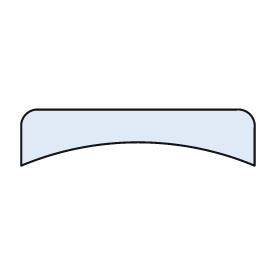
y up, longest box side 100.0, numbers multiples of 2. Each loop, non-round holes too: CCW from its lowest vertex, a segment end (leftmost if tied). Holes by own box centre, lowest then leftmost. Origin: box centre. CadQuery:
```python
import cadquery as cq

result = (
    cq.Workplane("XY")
    .moveTo(-50.0, -12.0)
    .threePointArc((0.0, -2.0), (50.0, -12.0))
    .lineTo(50.0, 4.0)
    .threePointArc((48.0, 10.0), (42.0, 12.0))
    .lineTo(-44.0, 12.0)
    .threePointArc((-48.0, 10.0), (-50.0, 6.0))
    .close()
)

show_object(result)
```